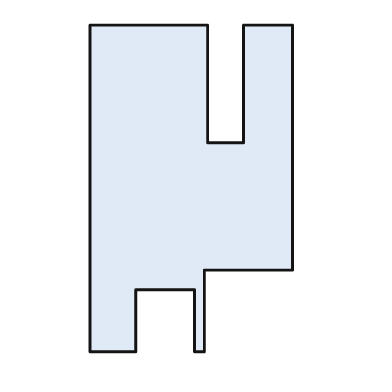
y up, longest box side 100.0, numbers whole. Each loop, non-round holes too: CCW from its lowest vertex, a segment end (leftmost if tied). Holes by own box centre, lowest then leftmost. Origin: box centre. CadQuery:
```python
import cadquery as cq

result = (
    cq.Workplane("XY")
    .moveTo(-31.0, -50.0)
    .lineTo(-17.0, -50.0)
    .lineTo(-17.0, -31.0)
    .lineTo(1.0, -31.0)
    .lineTo(1.0, -50.0)
    .lineTo(4.0, -50.0)
    .lineTo(4.0, -25.0)
    .lineTo(31.0, -25.0)
    .lineTo(31.0, 50.0)
    .lineTo(16.0, 50.0)
    .lineTo(16.0, 14.0)
    .lineTo(5.0, 14.0)
    .lineTo(5.0, 50.0)
    .lineTo(-31.0, 50.0)
    .close()
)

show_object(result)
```